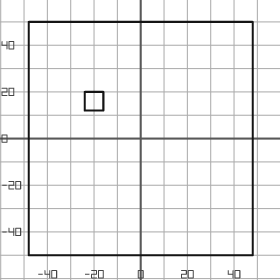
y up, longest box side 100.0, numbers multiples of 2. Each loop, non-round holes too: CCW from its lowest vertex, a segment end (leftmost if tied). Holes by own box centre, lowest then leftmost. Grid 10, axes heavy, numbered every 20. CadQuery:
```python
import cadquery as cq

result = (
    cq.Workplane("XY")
    .moveTo(-48.0, -50.0)
    .lineTo(48.0, -50.0)
    .lineTo(48.0, 50.0)
    .lineTo(-48.0, 50.0)
    .close()
    .moveTo(-24.0, 12.0)
    .lineTo(-16.0, 12.0)
    .lineTo(-16.0, 20.0)
    .lineTo(-24.0, 20.0)
    .close()
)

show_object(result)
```